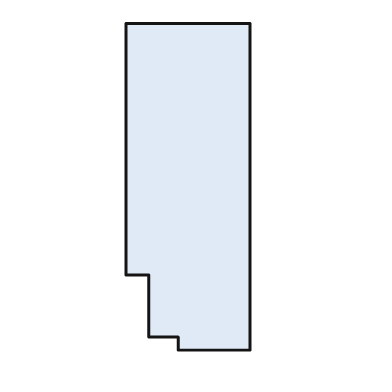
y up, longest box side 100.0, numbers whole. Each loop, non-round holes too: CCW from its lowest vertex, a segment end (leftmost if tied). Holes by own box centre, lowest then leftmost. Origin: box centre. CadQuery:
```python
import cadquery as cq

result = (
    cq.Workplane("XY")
    .moveTo(-3.0, -50.0)
    .lineTo(19.0, -50.0)
    .lineTo(19.0, 50.0)
    .lineTo(-19.0, 50.0)
    .lineTo(-19.0, -27.0)
    .lineTo(-12.0, -27.0)
    .lineTo(-12.0, -46.0)
    .lineTo(-3.0, -46.0)
    .close()
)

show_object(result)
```